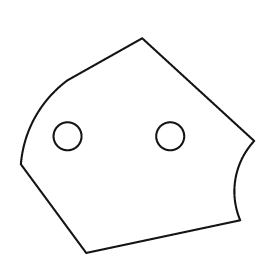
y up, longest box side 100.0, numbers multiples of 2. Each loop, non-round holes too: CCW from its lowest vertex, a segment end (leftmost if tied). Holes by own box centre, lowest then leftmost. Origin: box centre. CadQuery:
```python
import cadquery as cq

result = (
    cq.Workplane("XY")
    .moveTo(-22.0, -46.0)
    .lineTo(44.0, -32.0)
    .threePointArc((42.0, -14.0), (50.0, 2.0))
    .lineTo(2.0, 46.0)
    .lineTo(-30.0, 28.0)
    .threePointArc((-44.0, 12.0), (-50.0, -8.0))
    .close()
    .moveTo(-30.0, 4.0)
    .circle(6.0)
    .moveTo(14.0, 4.0)
    .circle(6.0)
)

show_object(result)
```